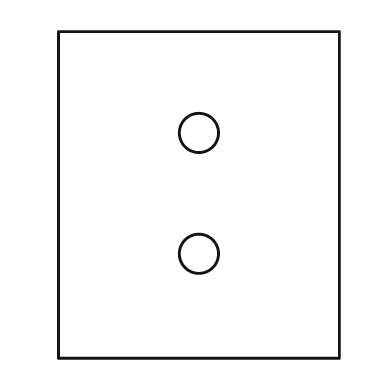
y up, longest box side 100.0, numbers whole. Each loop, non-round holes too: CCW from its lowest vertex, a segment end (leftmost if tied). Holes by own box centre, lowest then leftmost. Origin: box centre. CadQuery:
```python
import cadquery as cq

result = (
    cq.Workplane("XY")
    .moveTo(-43.0, -50.0)
    .lineTo(43.0, -50.0)
    .lineTo(43.0, 50.0)
    .lineTo(-43.0, 50.0)
    .close()
    .moveTo(0.0, -18.0)
    .circle(6.0)
    .moveTo(0.0, 19.0)
    .circle(6.0)
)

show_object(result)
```